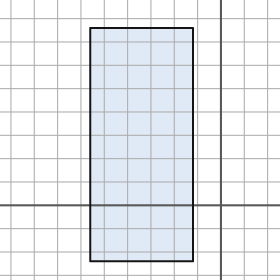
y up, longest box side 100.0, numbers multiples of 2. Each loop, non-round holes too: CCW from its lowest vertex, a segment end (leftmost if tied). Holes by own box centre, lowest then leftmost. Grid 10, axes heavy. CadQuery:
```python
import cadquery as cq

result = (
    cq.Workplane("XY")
    .moveTo(-56.0, -24.0)
    .lineTo(-12.0, -24.0)
    .lineTo(-12.0, 76.0)
    .lineTo(-56.0, 76.0)
    .close()
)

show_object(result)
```